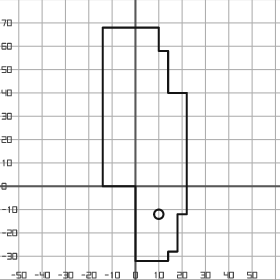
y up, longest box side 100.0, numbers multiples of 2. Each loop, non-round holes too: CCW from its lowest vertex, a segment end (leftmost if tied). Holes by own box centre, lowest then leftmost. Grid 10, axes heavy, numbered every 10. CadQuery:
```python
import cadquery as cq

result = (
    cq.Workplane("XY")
    .moveTo(0.0, -32.0)
    .lineTo(14.0, -32.0)
    .lineTo(14.0, -28.0)
    .lineTo(18.0, -28.0)
    .lineTo(18.0, -12.0)
    .lineTo(22.0, -12.0)
    .lineTo(22.0, 40.0)
    .lineTo(14.0, 40.0)
    .lineTo(14.0, 58.0)
    .lineTo(10.0, 58.0)
    .lineTo(10.0, 68.0)
    .lineTo(-14.0, 68.0)
    .lineTo(-14.0, 0.0)
    .lineTo(0.0, 0.0)
    .close()
    .moveTo(10.0, -12.0)
    .circle(2.0)
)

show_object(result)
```